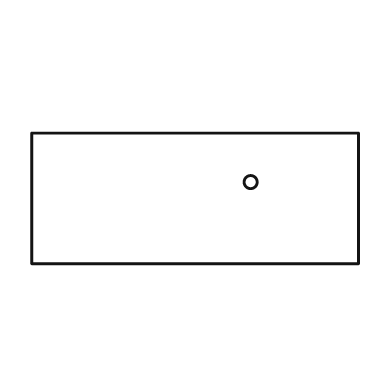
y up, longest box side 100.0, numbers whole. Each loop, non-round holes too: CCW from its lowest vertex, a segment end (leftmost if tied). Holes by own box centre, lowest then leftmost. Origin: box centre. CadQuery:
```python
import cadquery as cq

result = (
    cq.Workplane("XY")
    .moveTo(-50.0, -20.0)
    .lineTo(50.0, -20.0)
    .lineTo(50.0, 20.0)
    .lineTo(-50.0, 20.0)
    .close()
    .moveTo(17.0, 5.0)
    .circle(2.0)
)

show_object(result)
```